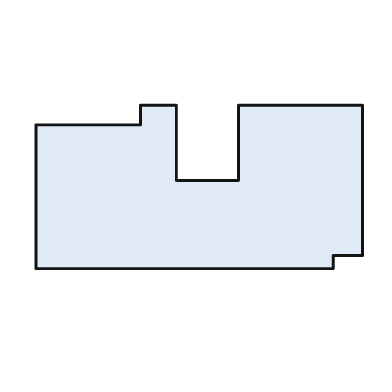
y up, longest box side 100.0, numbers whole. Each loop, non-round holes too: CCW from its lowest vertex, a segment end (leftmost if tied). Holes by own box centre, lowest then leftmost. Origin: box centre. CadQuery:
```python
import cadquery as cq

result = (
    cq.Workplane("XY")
    .moveTo(-50.0, -25.0)
    .lineTo(41.0, -25.0)
    .lineTo(41.0, -21.0)
    .lineTo(50.0, -21.0)
    .lineTo(50.0, 25.0)
    .lineTo(12.0, 25.0)
    .lineTo(12.0, 2.0)
    .lineTo(-7.0, 2.0)
    .lineTo(-7.0, 25.0)
    .lineTo(-18.0, 25.0)
    .lineTo(-18.0, 19.0)
    .lineTo(-50.0, 19.0)
    .close()
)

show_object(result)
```